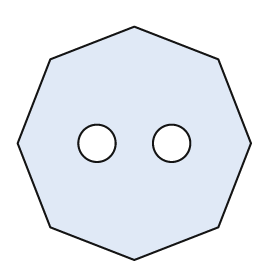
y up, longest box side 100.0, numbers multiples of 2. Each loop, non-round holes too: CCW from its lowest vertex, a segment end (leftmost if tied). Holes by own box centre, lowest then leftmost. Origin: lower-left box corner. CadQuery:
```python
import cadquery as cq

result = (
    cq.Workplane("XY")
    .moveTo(50.0, 0.0)
    .lineTo(86.0, 14.0)
    .lineTo(100.0, 50.0)
    .lineTo(86.0, 86.0)
    .lineTo(50.0, 100.0)
    .lineTo(14.0, 86.0)
    .lineTo(0.0, 50.0)
    .lineTo(14.0, 14.0)
    .close()
    .moveTo(34.0, 50.0)
    .circle(8.0)
    .moveTo(66.0, 50.0)
    .circle(8.0)
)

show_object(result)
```